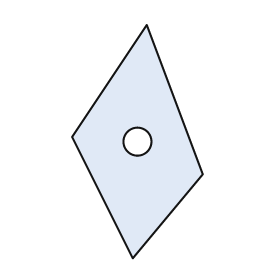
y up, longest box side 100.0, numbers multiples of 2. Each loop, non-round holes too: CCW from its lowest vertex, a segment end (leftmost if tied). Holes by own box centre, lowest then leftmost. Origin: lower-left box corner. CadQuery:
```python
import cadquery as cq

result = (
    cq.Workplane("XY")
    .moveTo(26.0, 0.0)
    .lineTo(56.0, 36.0)
    .lineTo(32.0, 100.0)
    .lineTo(0.0, 52.0)
    .close()
    .moveTo(28.0, 50.0)
    .circle(6.0)
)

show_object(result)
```